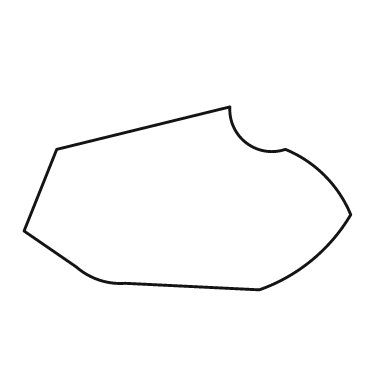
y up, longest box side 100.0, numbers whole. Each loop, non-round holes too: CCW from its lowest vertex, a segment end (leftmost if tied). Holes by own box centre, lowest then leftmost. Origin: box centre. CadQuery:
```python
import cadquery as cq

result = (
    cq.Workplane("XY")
    .moveTo(22.0, -28.0)
    .threePointArc((38.0, -19.0), (50.0, -5.0))
    .threePointArc((42.0, 7.0), (30.0, 15.0))
    .threePointArc((18.0, 17.0), (13.0, 28.0))
    .lineTo(-40.0, 15.0)
    .lineTo(-50.0, -10.0)
    .lineTo(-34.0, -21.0)
    .threePointArc((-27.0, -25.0), (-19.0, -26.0))
    .close()
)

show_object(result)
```